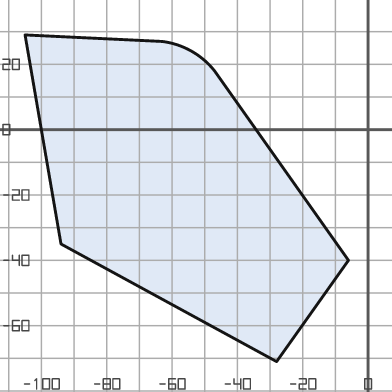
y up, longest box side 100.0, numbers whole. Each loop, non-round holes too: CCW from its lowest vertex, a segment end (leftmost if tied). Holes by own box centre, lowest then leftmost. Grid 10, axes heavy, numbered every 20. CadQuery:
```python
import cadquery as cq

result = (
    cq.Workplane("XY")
    .moveTo(-28.0, -71.0)
    .lineTo(-6.0, -40.0)
    .lineTo(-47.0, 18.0)
    .threePointArc((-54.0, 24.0), (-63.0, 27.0))
    .lineTo(-105.0, 29.0)
    .lineTo(-94.0, -35.0)
    .close()
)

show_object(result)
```